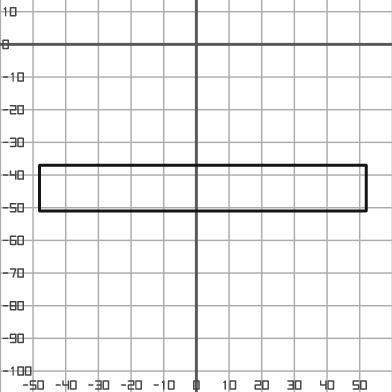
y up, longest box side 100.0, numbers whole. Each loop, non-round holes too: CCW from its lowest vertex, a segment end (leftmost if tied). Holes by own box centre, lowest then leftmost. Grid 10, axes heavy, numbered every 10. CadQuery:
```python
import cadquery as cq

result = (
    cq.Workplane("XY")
    .moveTo(-48.0, -51.0)
    .lineTo(52.0, -51.0)
    .lineTo(52.0, -37.0)
    .lineTo(-48.0, -37.0)
    .close()
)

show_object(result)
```